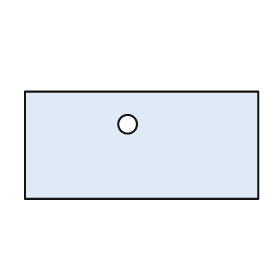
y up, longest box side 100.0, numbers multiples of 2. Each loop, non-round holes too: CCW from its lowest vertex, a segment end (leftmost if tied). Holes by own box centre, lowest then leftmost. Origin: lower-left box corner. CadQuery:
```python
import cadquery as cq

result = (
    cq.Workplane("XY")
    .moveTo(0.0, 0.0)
    .lineTo(100.0, 0.0)
    .lineTo(100.0, 46.0)
    .lineTo(0.0, 46.0)
    .close()
    .moveTo(44.0, 32.0)
    .circle(4.0)
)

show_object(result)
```